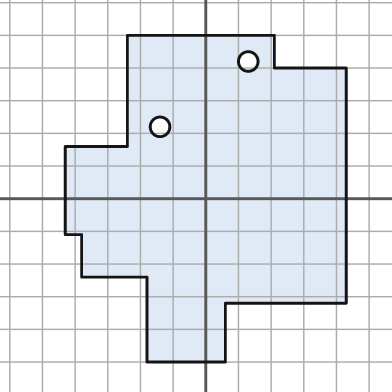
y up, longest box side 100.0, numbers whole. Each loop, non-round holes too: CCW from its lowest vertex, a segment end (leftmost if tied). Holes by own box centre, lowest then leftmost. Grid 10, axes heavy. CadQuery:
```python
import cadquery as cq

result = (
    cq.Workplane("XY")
    .moveTo(-18.0, -50.0)
    .lineTo(6.0, -50.0)
    .lineTo(6.0, -32.0)
    .lineTo(43.0, -32.0)
    .lineTo(43.0, 40.0)
    .lineTo(21.0, 40.0)
    .lineTo(21.0, 50.0)
    .lineTo(-24.0, 50.0)
    .lineTo(-24.0, 16.0)
    .lineTo(-43.0, 16.0)
    .lineTo(-43.0, -11.0)
    .lineTo(-38.0, -11.0)
    .lineTo(-38.0, -24.0)
    .lineTo(-18.0, -24.0)
    .close()
    .moveTo(-14.0, 22.0)
    .circle(3.0)
    .moveTo(13.0, 42.0)
    .circle(3.0)
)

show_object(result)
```